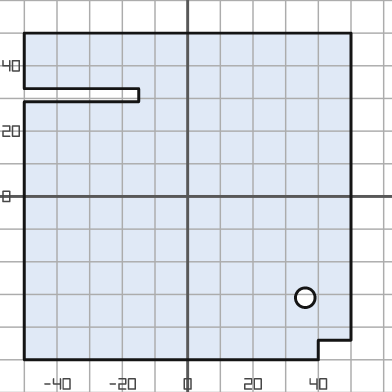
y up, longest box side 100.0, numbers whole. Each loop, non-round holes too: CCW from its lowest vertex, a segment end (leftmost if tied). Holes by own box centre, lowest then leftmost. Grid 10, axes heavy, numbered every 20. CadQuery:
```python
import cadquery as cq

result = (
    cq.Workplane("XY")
    .moveTo(-50.0, -50.0)
    .lineTo(40.0, -50.0)
    .lineTo(40.0, -44.0)
    .lineTo(50.0, -44.0)
    .lineTo(50.0, 50.0)
    .lineTo(-50.0, 50.0)
    .lineTo(-50.0, 33.0)
    .lineTo(-15.0, 33.0)
    .lineTo(-15.0, 29.0)
    .lineTo(-50.0, 29.0)
    .close()
    .moveTo(36.0, -31.0)
    .circle(3.0)
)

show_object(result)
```